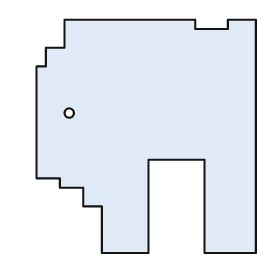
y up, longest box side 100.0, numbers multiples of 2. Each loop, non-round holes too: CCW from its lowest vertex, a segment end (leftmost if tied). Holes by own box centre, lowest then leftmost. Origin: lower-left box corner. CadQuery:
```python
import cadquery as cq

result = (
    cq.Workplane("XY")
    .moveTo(28.0, 0.0)
    .lineTo(48.0, 0.0)
    .lineTo(48.0, 40.0)
    .lineTo(72.0, 40.0)
    .lineTo(72.0, 0.0)
    .lineTo(94.0, 0.0)
    .lineTo(94.0, 100.0)
    .lineTo(82.0, 100.0)
    .lineTo(82.0, 96.0)
    .lineTo(68.0, 96.0)
    .lineTo(68.0, 100.0)
    .lineTo(12.0, 100.0)
    .lineTo(12.0, 88.0)
    .lineTo(4.0, 88.0)
    .lineTo(4.0, 80.0)
    .lineTo(0.0, 80.0)
    .lineTo(0.0, 32.0)
    .lineTo(10.0, 32.0)
    .lineTo(10.0, 28.0)
    .lineTo(20.0, 28.0)
    .lineTo(20.0, 20.0)
    .lineTo(28.0, 20.0)
    .close()
    .moveTo(14.0, 60.0)
    .circle(2.0)
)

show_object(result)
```